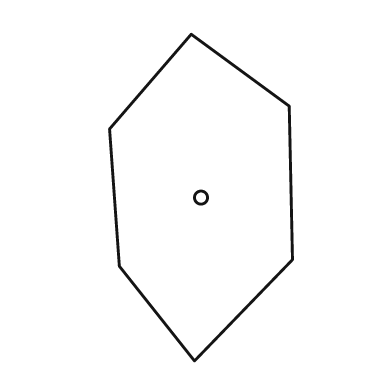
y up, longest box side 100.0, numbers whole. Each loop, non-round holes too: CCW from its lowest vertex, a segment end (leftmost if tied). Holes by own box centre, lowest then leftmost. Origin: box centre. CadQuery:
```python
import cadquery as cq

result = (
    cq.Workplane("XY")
    .moveTo(-2.0, -50.0)
    .lineTo(28.0, -19.0)
    .lineTo(27.0, 28.0)
    .lineTo(-3.0, 50.0)
    .lineTo(-28.0, 21.0)
    .lineTo(-25.0, -21.0)
    .close()
    .moveTo(0.0, 0.0)
    .circle(2.0)
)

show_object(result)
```